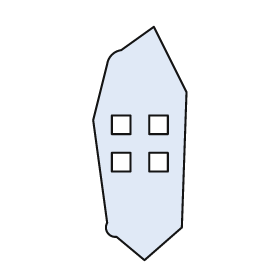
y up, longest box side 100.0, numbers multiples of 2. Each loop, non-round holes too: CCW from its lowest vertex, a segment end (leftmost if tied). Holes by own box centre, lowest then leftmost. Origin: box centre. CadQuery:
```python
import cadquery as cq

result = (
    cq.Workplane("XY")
    .moveTo(2.0, -50.0)
    .lineTo(18.0, -36.0)
    .lineTo(20.0, 22.0)
    .lineTo(6.0, 50.0)
    .lineTo(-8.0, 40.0)
    .threePointArc((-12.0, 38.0), (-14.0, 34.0))
    .lineTo(-20.0, 10.0)
    .lineTo(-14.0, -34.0)
    .threePointArc((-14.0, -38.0), (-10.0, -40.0))
    .close()
    .moveTo(-12.0, -12.0)
    .lineTo(-4.0, -12.0)
    .lineTo(-4.0, -4.0)
    .lineTo(-12.0, -4.0)
    .close()
    .moveTo(4.0, -12.0)
    .lineTo(12.0, -12.0)
    .lineTo(12.0, -4.0)
    .lineTo(4.0, -4.0)
    .close()
    .moveTo(-12.0, 4.0)
    .lineTo(-4.0, 4.0)
    .lineTo(-4.0, 12.0)
    .lineTo(-12.0, 12.0)
    .close()
    .moveTo(4.0, 4.0)
    .lineTo(12.0, 4.0)
    .lineTo(12.0, 12.0)
    .lineTo(4.0, 12.0)
    .close()
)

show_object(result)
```